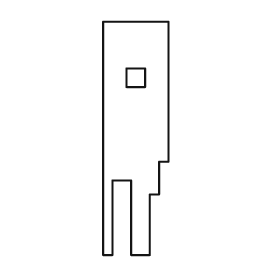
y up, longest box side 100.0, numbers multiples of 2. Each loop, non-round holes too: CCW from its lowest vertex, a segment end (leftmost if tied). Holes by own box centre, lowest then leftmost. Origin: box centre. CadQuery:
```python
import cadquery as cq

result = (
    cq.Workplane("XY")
    .moveTo(-14.0, -50.0)
    .lineTo(-10.0, -50.0)
    .lineTo(-10.0, -18.0)
    .lineTo(-2.0, -18.0)
    .lineTo(-2.0, -50.0)
    .lineTo(6.0, -50.0)
    .lineTo(6.0, -24.0)
    .lineTo(10.0, -24.0)
    .lineTo(10.0, -10.0)
    .lineTo(14.0, -10.0)
    .lineTo(14.0, 50.0)
    .lineTo(-14.0, 50.0)
    .close()
    .moveTo(-4.0, 22.0)
    .lineTo(4.0, 22.0)
    .lineTo(4.0, 30.0)
    .lineTo(-4.0, 30.0)
    .close()
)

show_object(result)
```